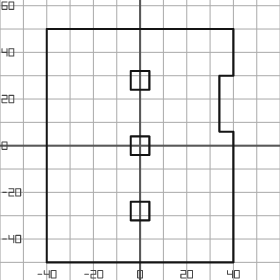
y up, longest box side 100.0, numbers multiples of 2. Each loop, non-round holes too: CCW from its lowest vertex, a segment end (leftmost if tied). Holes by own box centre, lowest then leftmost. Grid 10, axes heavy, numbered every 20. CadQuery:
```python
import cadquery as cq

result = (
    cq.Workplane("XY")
    .moveTo(-40.0, -50.0)
    .lineTo(40.0, -50.0)
    .lineTo(40.0, 6.0)
    .lineTo(34.0, 6.0)
    .lineTo(34.0, 30.0)
    .lineTo(40.0, 30.0)
    .lineTo(40.0, 50.0)
    .lineTo(-40.0, 50.0)
    .close()
    .moveTo(-4.0, -32.0)
    .lineTo(4.0, -32.0)
    .lineTo(4.0, -24.0)
    .lineTo(-4.0, -24.0)
    .close()
    .moveTo(-4.0, -4.0)
    .lineTo(4.0, -4.0)
    .lineTo(4.0, 4.0)
    .lineTo(-4.0, 4.0)
    .close()
    .moveTo(-4.0, 24.0)
    .lineTo(4.0, 24.0)
    .lineTo(4.0, 32.0)
    .lineTo(-4.0, 32.0)
    .close()
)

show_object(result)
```